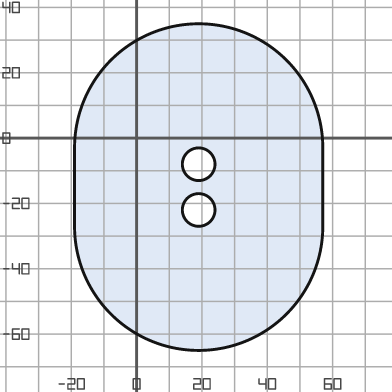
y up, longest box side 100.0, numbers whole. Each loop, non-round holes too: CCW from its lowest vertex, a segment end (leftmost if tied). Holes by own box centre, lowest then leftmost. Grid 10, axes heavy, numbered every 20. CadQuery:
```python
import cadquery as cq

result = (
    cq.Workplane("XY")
    .moveTo(-19.0, -27.0)
    .threePointArc((19.0, -65.0), (57.0, -27.0))
    .lineTo(57.0, -3.0)
    .threePointArc((19.0, 35.0), (-19.0, -3.0))
    .close()
    .moveTo(19.0, -22.0)
    .circle(5.0)
    .moveTo(19.0, -8.0)
    .circle(5.0)
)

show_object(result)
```